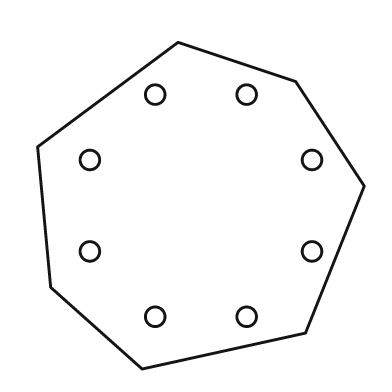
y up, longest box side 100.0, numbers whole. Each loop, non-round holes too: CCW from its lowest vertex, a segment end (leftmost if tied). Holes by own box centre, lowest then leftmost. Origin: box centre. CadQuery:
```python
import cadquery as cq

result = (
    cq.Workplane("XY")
    .moveTo(-18.0, -50.0)
    .lineTo(32.0, -39.0)
    .lineTo(50.0, 6.0)
    .lineTo(29.0, 38.0)
    .lineTo(-7.0, 50.0)
    .lineTo(-50.0, 18.0)
    .lineTo(-46.0, -25.0)
    .close()
    .moveTo(-14.0, -34.0)
    .circle(3.0)
    .moveTo(14.0, -34.0)
    .circle(3.0)
    .moveTo(-34.0, -14.0)
    .circle(3.0)
    .moveTo(34.0, -14.0)
    .circle(3.0)
    .moveTo(-34.0, 14.0)
    .circle(3.0)
    .moveTo(34.0, 14.0)
    .circle(3.0)
    .moveTo(-14.0, 34.0)
    .circle(3.0)
    .moveTo(14.0, 34.0)
    .circle(3.0)
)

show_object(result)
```